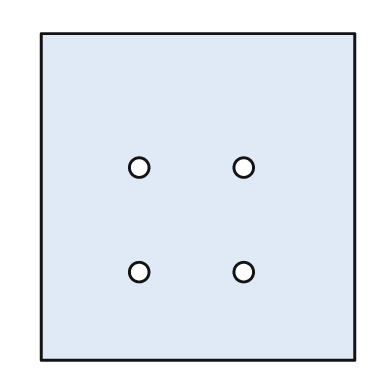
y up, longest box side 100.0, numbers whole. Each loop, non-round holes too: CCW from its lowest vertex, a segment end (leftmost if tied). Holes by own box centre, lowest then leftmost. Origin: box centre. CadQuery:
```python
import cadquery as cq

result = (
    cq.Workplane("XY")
    .moveTo(-48.0, -50.0)
    .lineTo(48.0, -50.0)
    .lineTo(48.0, 50.0)
    .lineTo(-48.0, 50.0)
    .close()
    .moveTo(-18.0, -23.0)
    .circle(3.0)
    .moveTo(14.0, -23.0)
    .circle(3.0)
    .moveTo(-18.0, 9.0)
    .circle(3.0)
    .moveTo(14.0, 9.0)
    .circle(3.0)
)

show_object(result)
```